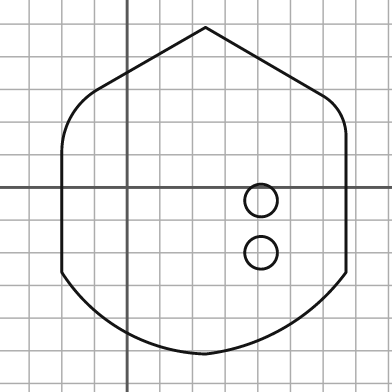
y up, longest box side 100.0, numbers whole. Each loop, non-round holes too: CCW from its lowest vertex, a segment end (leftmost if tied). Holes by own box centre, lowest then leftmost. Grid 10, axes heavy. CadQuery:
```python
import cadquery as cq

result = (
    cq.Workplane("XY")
    .moveTo(24.0, -51.0)
    .threePointArc((48.0, -43.0), (67.0, -26.0))
    .lineTo(67.0, 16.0)
    .threePointArc((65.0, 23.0), (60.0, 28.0))
    .lineTo(24.0, 49.0)
    .lineTo(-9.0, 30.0)
    .threePointArc((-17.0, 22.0), (-20.0, 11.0))
    .lineTo(-20.0, -26.0)
    .threePointArc((-1.0, -44.0), (24.0, -51.0))
    .close()
    .moveTo(41.0, -20.0)
    .circle(5.0)
    .moveTo(41.0, -4.0)
    .circle(5.0)
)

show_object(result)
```